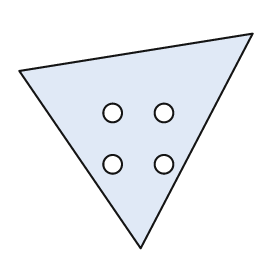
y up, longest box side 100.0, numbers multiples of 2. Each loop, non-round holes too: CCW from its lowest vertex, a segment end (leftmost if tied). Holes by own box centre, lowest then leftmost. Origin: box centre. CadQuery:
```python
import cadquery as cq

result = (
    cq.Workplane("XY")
    .moveTo(2.0, -46.0)
    .lineTo(50.0, 46.0)
    .lineTo(-50.0, 30.0)
    .close()
    .moveTo(-10.0, -10.0)
    .circle(4.0)
    .moveTo(12.0, -10.0)
    .circle(4.0)
    .moveTo(-10.0, 12.0)
    .circle(4.0)
    .moveTo(12.0, 12.0)
    .circle(4.0)
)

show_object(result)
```